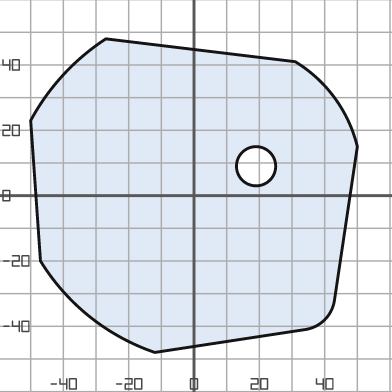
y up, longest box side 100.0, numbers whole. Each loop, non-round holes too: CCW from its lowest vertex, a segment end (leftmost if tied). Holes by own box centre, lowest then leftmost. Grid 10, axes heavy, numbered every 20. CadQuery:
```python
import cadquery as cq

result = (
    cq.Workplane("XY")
    .moveTo(-12.0, -48.0)
    .lineTo(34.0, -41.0)
    .threePointArc((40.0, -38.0), (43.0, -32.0))
    .lineTo(50.0, 15.0)
    .threePointArc((43.0, 30.0), (31.0, 41.0))
    .lineTo(-27.0, 48.0)
    .threePointArc((-40.0, 37.0), (-50.0, 23.0))
    .lineTo(-47.0, -20.0)
    .threePointArc((-32.0, -37.0), (-12.0, -48.0))
    .close()
    .moveTo(19.0, 9.0)
    .circle(6.0)
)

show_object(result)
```